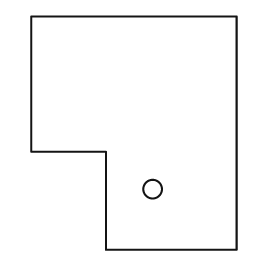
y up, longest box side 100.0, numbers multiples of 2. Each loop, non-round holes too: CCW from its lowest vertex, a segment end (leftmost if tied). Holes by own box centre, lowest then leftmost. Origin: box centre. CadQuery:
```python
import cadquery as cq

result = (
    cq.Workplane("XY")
    .moveTo(-12.0, -50.0)
    .lineTo(44.0, -50.0)
    .lineTo(44.0, 50.0)
    .lineTo(-44.0, 50.0)
    .lineTo(-44.0, -8.0)
    .lineTo(-12.0, -8.0)
    .close()
    .moveTo(8.0, -24.0)
    .circle(4.0)
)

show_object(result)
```